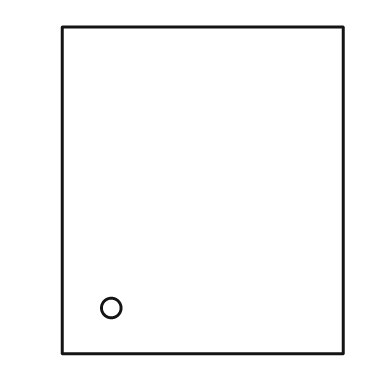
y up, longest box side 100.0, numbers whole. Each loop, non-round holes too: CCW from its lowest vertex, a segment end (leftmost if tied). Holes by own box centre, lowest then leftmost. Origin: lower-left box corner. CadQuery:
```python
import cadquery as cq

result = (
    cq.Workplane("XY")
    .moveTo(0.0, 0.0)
    .lineTo(86.0, 0.0)
    .lineTo(86.0, 100.0)
    .lineTo(0.0, 100.0)
    .close()
    .moveTo(15.0, 14.0)
    .circle(3.0)
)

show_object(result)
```